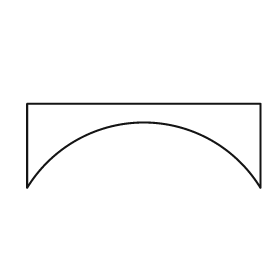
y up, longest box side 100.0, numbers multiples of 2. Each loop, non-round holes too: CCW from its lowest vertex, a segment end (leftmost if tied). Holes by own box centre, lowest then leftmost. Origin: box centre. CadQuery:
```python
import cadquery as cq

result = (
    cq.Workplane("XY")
    .moveTo(-50.0, -18.0)
    .threePointArc((0.0, 10.0), (50.0, -18.0))
    .lineTo(50.0, 18.0)
    .lineTo(-50.0, 18.0)
    .close()
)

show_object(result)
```